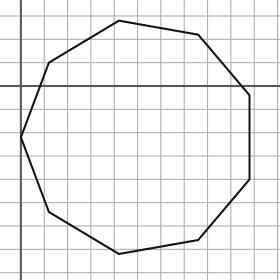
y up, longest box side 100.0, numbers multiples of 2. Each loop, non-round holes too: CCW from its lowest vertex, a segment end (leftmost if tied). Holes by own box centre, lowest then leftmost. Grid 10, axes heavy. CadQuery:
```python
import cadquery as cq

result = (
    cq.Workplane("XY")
    .moveTo(42.0, -72.0)
    .lineTo(76.0, -66.0)
    .lineTo(98.0, -40.0)
    .lineTo(98.0, -4.0)
    .lineTo(76.0, 22.0)
    .lineTo(42.0, 28.0)
    .lineTo(12.0, 10.0)
    .lineTo(0.0, -22.0)
    .lineTo(12.0, -54.0)
    .close()
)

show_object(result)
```